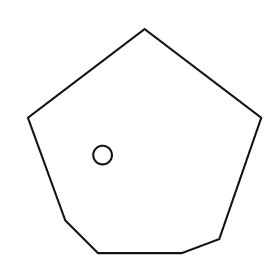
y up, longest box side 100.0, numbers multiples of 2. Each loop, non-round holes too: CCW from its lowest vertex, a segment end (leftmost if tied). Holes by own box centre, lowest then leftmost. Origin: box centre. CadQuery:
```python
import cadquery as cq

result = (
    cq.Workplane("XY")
    .moveTo(-20.0, -48.0)
    .lineTo(16.0, -48.0)
    .lineTo(32.0, -42.0)
    .lineTo(50.0, 10.0)
    .lineTo(0.0, 48.0)
    .lineTo(-50.0, 10.0)
    .lineTo(-34.0, -34.0)
    .close()
    .moveTo(-18.0, -6.0)
    .circle(4.0)
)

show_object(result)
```